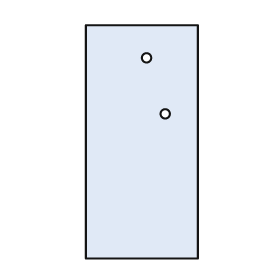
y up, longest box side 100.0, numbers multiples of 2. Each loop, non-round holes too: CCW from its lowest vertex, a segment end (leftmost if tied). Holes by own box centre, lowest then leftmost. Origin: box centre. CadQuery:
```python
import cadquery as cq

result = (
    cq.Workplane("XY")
    .moveTo(-24.0, -50.0)
    .lineTo(24.0, -50.0)
    .lineTo(24.0, 50.0)
    .lineTo(-24.0, 50.0)
    .close()
    .moveTo(10.0, 12.0)
    .circle(2.0)
    .moveTo(2.0, 36.0)
    .circle(2.0)
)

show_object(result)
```